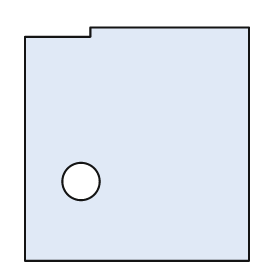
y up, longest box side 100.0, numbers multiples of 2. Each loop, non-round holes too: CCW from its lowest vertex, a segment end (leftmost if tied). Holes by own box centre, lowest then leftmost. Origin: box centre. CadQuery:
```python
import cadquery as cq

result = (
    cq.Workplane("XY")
    .moveTo(-48.0, -50.0)
    .lineTo(48.0, -50.0)
    .lineTo(48.0, 50.0)
    .lineTo(-20.0, 50.0)
    .lineTo(-20.0, 46.0)
    .lineTo(-48.0, 46.0)
    .close()
    .moveTo(-24.0, -16.0)
    .circle(8.0)
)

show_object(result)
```